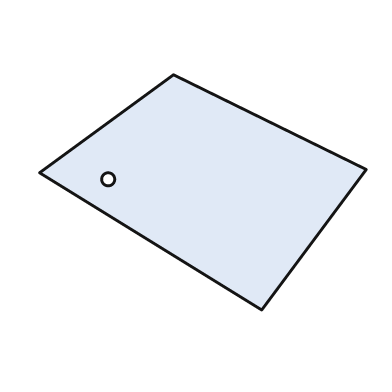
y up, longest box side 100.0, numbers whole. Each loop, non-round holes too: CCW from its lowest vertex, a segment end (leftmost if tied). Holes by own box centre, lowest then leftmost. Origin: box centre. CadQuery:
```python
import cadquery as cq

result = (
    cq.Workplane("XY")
    .moveTo(18.0, -36.0)
    .lineTo(50.0, 7.0)
    .lineTo(-9.0, 36.0)
    .lineTo(-50.0, 6.0)
    .close()
    .moveTo(-29.0, 4.0)
    .circle(2.0)
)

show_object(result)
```